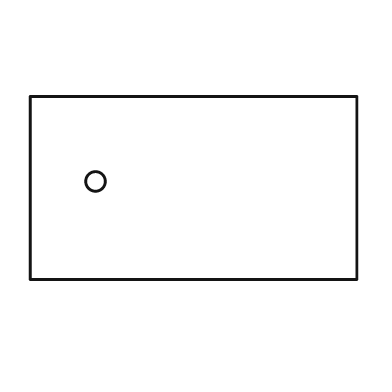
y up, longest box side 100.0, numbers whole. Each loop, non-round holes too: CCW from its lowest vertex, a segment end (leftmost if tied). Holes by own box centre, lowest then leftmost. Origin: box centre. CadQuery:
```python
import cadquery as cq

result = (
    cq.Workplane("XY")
    .moveTo(-50.0, -28.0)
    .lineTo(50.0, -28.0)
    .lineTo(50.0, 28.0)
    .lineTo(-50.0, 28.0)
    .close()
    .moveTo(-30.0, 2.0)
    .circle(3.0)
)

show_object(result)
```